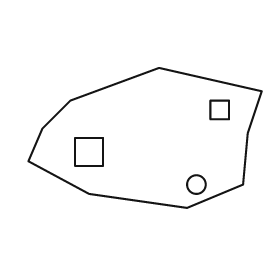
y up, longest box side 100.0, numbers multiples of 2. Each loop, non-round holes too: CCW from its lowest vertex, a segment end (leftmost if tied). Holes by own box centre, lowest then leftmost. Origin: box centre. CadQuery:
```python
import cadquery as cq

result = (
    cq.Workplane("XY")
    .moveTo(18.0, -30.0)
    .lineTo(42.0, -20.0)
    .lineTo(44.0, 2.0)
    .lineTo(50.0, 20.0)
    .lineTo(6.0, 30.0)
    .lineTo(-32.0, 16.0)
    .lineTo(-44.0, 4.0)
    .lineTo(-50.0, -10.0)
    .lineTo(-24.0, -24.0)
    .close()
    .moveTo(22.0, -20.0)
    .circle(4.0)
    .moveTo(-30.0, -12.0)
    .lineTo(-18.0, -12.0)
    .lineTo(-18.0, 0.0)
    .lineTo(-30.0, 0.0)
    .close()
    .moveTo(28.0, 8.0)
    .lineTo(36.0, 8.0)
    .lineTo(36.0, 16.0)
    .lineTo(28.0, 16.0)
    .close()
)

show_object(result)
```